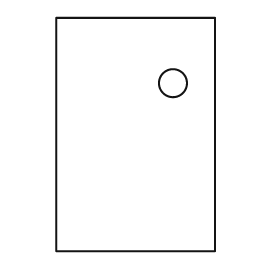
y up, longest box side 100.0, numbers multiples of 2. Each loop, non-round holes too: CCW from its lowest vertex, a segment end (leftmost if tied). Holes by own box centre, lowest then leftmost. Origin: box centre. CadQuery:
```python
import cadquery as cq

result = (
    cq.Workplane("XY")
    .moveTo(-34.0, -50.0)
    .lineTo(34.0, -50.0)
    .lineTo(34.0, 50.0)
    .lineTo(-34.0, 50.0)
    .close()
    .moveTo(16.0, 22.0)
    .circle(6.0)
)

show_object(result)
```